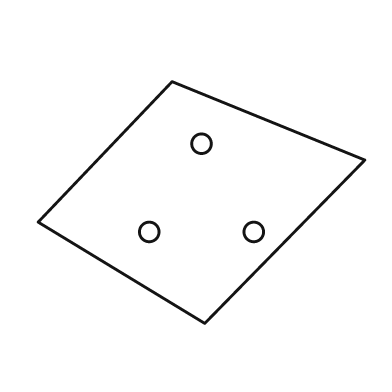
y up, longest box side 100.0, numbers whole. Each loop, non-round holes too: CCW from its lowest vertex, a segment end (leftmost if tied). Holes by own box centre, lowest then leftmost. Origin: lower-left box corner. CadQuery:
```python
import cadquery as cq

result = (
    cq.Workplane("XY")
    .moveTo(51.0, 0.0)
    .lineTo(100.0, 50.0)
    .lineTo(41.0, 74.0)
    .lineTo(0.0, 31.0)
    .close()
    .moveTo(34.0, 28.0)
    .circle(3.0)
    .moveTo(66.0, 28.0)
    .circle(3.0)
    .moveTo(50.0, 55.0)
    .circle(3.0)
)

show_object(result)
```